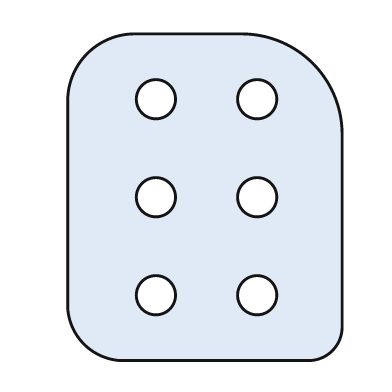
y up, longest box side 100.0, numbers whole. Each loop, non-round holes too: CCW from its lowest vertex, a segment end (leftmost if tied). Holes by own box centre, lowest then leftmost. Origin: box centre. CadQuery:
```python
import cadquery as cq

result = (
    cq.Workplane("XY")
    .moveTo(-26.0, -50.0)
    .lineTo(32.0, -50.0)
    .threePointArc((39.0, -47.0), (42.0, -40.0))
    .lineTo(42.0, 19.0)
    .threePointArc((33.0, 41.0), (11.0, 50.0))
    .lineTo(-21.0, 50.0)
    .threePointArc((-36.0, 44.0), (-42.0, 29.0))
    .lineTo(-42.0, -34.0)
    .threePointArc((-37.0, -45.0), (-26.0, -50.0))
    .close()
    .moveTo(-15.0, -30.0)
    .circle(6.0)
    .moveTo(16.0, -30.0)
    .circle(6.0)
    .moveTo(-15.0, 0.0)
    .circle(6.0)
    .moveTo(16.0, 0.0)
    .circle(6.0)
    .moveTo(-15.0, 30.0)
    .circle(6.0)
    .moveTo(16.0, 30.0)
    .circle(6.0)
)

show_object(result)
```